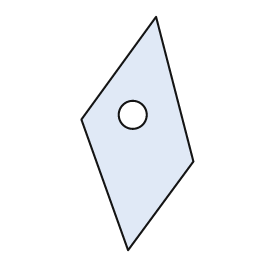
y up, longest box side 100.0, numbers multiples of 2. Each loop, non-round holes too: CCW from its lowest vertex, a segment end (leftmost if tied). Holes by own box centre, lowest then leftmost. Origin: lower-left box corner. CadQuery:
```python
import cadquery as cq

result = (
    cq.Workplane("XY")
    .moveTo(20.0, 0.0)
    .lineTo(48.0, 38.0)
    .lineTo(32.0, 100.0)
    .lineTo(0.0, 56.0)
    .close()
    .moveTo(22.0, 58.0)
    .circle(6.0)
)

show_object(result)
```